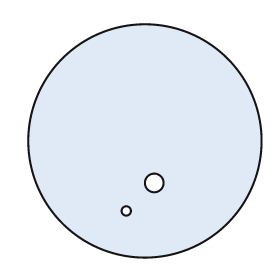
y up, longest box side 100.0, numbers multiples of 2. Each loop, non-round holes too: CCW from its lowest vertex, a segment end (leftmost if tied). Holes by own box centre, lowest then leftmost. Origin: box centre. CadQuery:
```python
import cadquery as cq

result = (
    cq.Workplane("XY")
    .moveTo(0.0, 0.0)
    .circle(50.0)
    .moveTo(-8.0, -30.0)
    .circle(2.0)
    .moveTo(4.0, -18.0)
    .circle(4.0)
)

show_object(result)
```